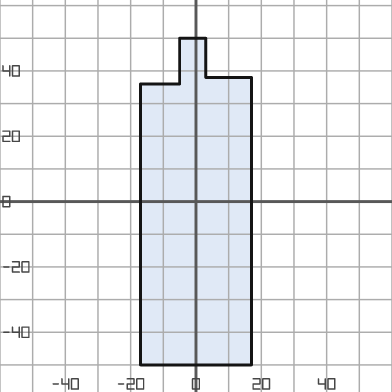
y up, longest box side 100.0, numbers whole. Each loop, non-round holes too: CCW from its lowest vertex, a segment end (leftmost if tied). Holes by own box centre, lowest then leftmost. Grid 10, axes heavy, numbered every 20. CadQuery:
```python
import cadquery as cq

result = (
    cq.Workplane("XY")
    .moveTo(-17.0, -50.0)
    .lineTo(17.0, -50.0)
    .lineTo(17.0, 38.0)
    .lineTo(3.0, 38.0)
    .lineTo(3.0, 50.0)
    .lineTo(-5.0, 50.0)
    .lineTo(-5.0, 36.0)
    .lineTo(-17.0, 36.0)
    .close()
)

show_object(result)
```